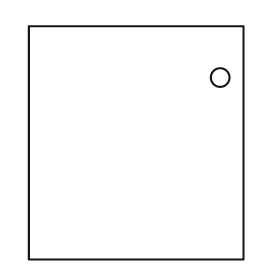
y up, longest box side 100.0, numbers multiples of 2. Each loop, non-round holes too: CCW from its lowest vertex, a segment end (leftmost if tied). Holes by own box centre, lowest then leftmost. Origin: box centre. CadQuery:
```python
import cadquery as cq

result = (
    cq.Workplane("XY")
    .moveTo(-46.0, -50.0)
    .lineTo(46.0, -50.0)
    .lineTo(46.0, 50.0)
    .lineTo(-46.0, 50.0)
    .close()
    .moveTo(36.0, 28.0)
    .circle(4.0)
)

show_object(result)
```